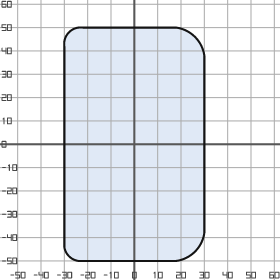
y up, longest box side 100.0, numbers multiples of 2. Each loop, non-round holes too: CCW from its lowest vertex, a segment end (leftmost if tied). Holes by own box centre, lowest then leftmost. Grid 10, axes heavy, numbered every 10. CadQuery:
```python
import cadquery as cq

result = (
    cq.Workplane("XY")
    .moveTo(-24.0, -50.0)
    .lineTo(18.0, -50.0)
    .threePointArc((26.0, -46.0), (30.0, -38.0))
    .lineTo(30.0, 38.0)
    .threePointArc((26.0, 46.0), (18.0, 50.0))
    .lineTo(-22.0, 50.0)
    .threePointArc((-28.0, 48.0), (-30.0, 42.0))
    .lineTo(-30.0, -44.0)
    .threePointArc((-28.0, -48.0), (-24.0, -50.0))
    .close()
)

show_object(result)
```